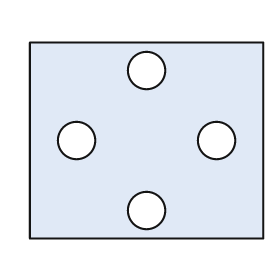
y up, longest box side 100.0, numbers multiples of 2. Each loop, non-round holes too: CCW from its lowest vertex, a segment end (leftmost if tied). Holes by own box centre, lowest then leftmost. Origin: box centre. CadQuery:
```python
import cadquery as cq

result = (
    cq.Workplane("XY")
    .moveTo(-50.0, -42.0)
    .lineTo(50.0, -42.0)
    .lineTo(50.0, 42.0)
    .lineTo(-50.0, 42.0)
    .close()
    .moveTo(0.0, -30.0)
    .circle(8.0)
    .moveTo(-30.0, 0.0)
    .circle(8.0)
    .moveTo(30.0, 0.0)
    .circle(8.0)
    .moveTo(0.0, 30.0)
    .circle(8.0)
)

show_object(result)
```